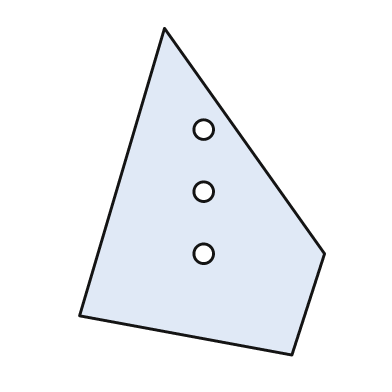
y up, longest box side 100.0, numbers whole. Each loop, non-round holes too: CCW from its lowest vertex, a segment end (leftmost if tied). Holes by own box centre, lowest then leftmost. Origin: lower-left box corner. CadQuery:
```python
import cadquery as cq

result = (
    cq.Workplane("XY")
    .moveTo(65.0, 0.0)
    .lineTo(75.0, 31.0)
    .lineTo(26.0, 100.0)
    .lineTo(0.0, 12.0)
    .close()
    .moveTo(38.0, 31.0)
    .circle(3.0)
    .moveTo(38.0, 50.0)
    .circle(3.0)
    .moveTo(38.0, 69.0)
    .circle(3.0)
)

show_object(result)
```